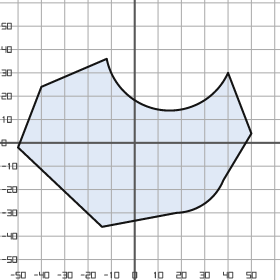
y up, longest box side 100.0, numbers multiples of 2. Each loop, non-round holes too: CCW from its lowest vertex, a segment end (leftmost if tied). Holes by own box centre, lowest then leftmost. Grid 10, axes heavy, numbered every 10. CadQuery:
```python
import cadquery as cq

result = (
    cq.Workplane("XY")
    .moveTo(-14.0, -36.0)
    .lineTo(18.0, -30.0)
    .threePointArc((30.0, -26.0), (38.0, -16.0))
    .lineTo(50.0, 4.0)
    .lineTo(40.0, 30.0)
    .threePointArc((12.0, 14.0), (-12.0, 36.0))
    .lineTo(-40.0, 24.0)
    .lineTo(-50.0, -2.0)
    .close()
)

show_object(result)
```